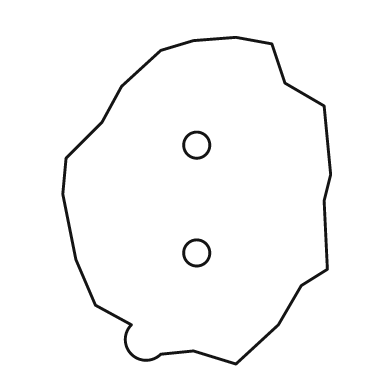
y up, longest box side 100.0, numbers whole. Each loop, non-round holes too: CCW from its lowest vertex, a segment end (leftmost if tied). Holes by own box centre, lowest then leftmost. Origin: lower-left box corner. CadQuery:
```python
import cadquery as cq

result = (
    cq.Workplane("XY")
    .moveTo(53.0, 0.0)
    .lineTo(66.0, 12.0)
    .lineTo(73.0, 24.0)
    .lineTo(81.0, 29.0)
    .lineTo(80.0, 50.0)
    .lineTo(82.0, 58.0)
    .lineTo(80.0, 79.0)
    .lineTo(68.0, 86.0)
    .lineTo(64.0, 98.0)
    .lineTo(53.0, 100.0)
    .lineTo(40.0, 99.0)
    .lineTo(30.0, 96.0)
    .lineTo(18.0, 85.0)
    .lineTo(12.0, 74.0)
    .lineTo(1.0, 63.0)
    .lineTo(0.0, 52.0)
    .lineTo(4.0, 32.0)
    .lineTo(10.0, 18.0)
    .lineTo(21.0, 12.0)
    .threePointArc((21.0, 3.0), (30.0, 3.0))
    .lineTo(40.0, 4.0)
    .close()
    .moveTo(41.0, 34.0)
    .circle(4.0)
    .moveTo(41.0, 67.0)
    .circle(4.0)
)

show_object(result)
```